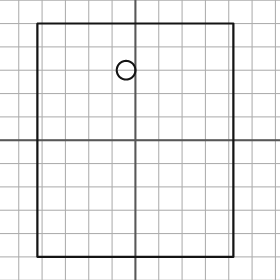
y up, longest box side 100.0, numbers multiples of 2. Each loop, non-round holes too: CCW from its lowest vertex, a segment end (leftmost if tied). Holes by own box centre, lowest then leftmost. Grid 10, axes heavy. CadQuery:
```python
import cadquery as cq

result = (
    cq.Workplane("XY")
    .moveTo(-42.0, -50.0)
    .lineTo(42.0, -50.0)
    .lineTo(42.0, 50.0)
    .lineTo(-42.0, 50.0)
    .close()
    .moveTo(-4.0, 30.0)
    .circle(4.0)
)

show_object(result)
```